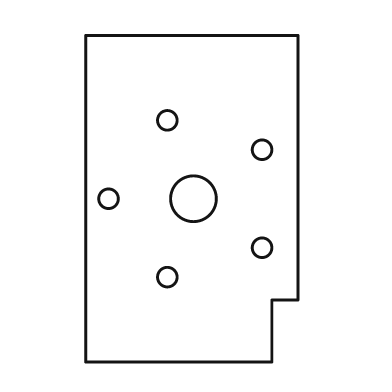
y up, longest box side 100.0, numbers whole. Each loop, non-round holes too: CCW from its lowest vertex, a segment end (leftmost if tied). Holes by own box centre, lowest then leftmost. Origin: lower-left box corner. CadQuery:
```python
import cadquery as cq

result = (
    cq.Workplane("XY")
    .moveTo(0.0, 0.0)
    .lineTo(57.0, 0.0)
    .lineTo(57.0, 19.0)
    .lineTo(65.0, 19.0)
    .lineTo(65.0, 100.0)
    .lineTo(0.0, 100.0)
    .close()
    .moveTo(25.0, 26.0)
    .circle(3.0)
    .moveTo(54.0, 35.0)
    .circle(3.0)
    .moveTo(7.0, 50.0)
    .circle(3.0)
    .moveTo(33.0, 50.0)
    .circle(7.0)
    .moveTo(54.0, 65.0)
    .circle(3.0)
    .moveTo(25.0, 74.0)
    .circle(3.0)
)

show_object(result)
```